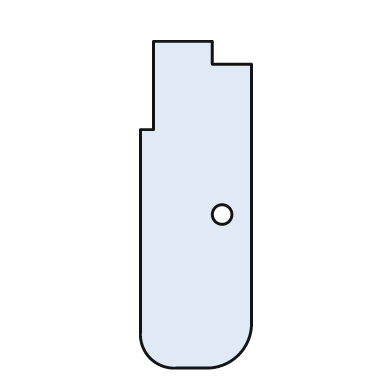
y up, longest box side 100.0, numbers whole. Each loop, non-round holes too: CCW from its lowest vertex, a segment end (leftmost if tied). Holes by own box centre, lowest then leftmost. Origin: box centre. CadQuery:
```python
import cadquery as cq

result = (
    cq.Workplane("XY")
    .moveTo(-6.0, -50.0)
    .lineTo(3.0, -50.0)
    .threePointArc((13.0, -46.0), (17.0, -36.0))
    .lineTo(17.0, 43.0)
    .lineTo(5.0, 43.0)
    .lineTo(5.0, 50.0)
    .lineTo(-13.0, 50.0)
    .lineTo(-13.0, 23.0)
    .lineTo(-17.0, 23.0)
    .lineTo(-17.0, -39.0)
    .threePointArc((-14.0, -47.0), (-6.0, -50.0))
    .close()
    .moveTo(8.0, -3.0)
    .circle(3.0)
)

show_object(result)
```